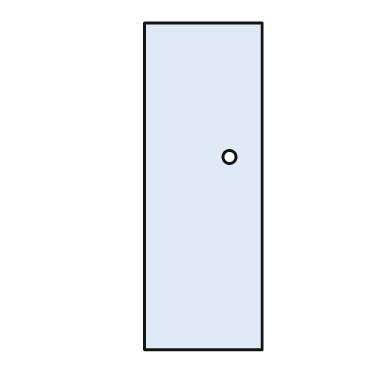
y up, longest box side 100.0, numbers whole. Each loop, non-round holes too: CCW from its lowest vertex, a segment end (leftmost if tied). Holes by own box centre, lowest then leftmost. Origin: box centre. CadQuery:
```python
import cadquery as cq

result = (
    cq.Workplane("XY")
    .moveTo(-18.0, -50.0)
    .lineTo(18.0, -50.0)
    .lineTo(18.0, 50.0)
    .lineTo(-18.0, 50.0)
    .close()
    .moveTo(8.0, 9.0)
    .circle(2.0)
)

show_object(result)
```